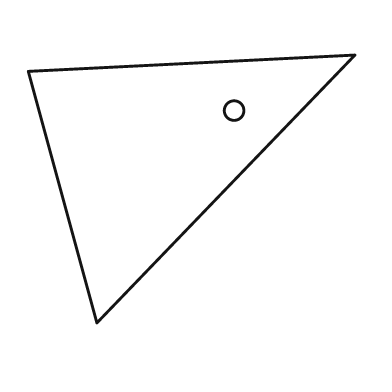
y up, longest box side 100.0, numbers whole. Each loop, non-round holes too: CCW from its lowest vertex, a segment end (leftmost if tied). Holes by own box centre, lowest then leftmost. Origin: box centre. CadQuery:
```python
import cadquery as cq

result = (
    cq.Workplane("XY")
    .moveTo(-29.0, -41.0)
    .lineTo(50.0, 41.0)
    .lineTo(-50.0, 36.0)
    .close()
    .moveTo(13.0, 24.0)
    .circle(3.0)
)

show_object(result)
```